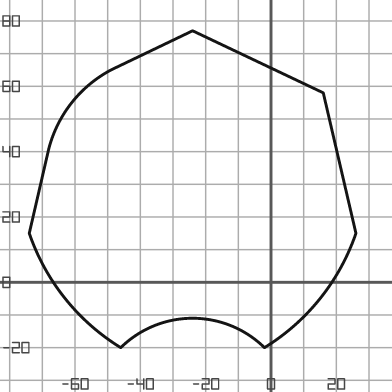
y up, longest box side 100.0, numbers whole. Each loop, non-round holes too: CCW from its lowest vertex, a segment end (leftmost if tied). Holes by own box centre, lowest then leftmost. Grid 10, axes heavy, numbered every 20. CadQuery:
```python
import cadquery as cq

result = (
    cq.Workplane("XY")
    .moveTo(-46.0, -20.0)
    .threePointArc((-24.0, -11.0), (-2.0, -20.0))
    .threePointArc((15.0, -5.0), (26.0, 15.0))
    .lineTo(16.0, 58.0)
    .lineTo(-24.0, 77.0)
    .lineTo(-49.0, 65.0)
    .threePointArc((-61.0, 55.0), (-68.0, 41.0))
    .lineTo(-74.0, 15.0)
    .threePointArc((-63.0, -5.0), (-46.0, -20.0))
    .close()
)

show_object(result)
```